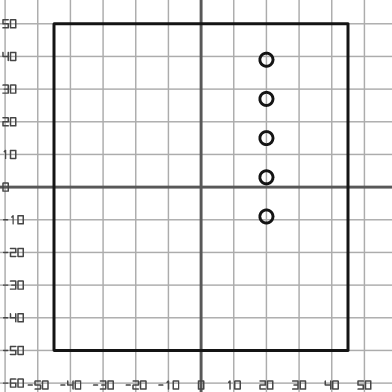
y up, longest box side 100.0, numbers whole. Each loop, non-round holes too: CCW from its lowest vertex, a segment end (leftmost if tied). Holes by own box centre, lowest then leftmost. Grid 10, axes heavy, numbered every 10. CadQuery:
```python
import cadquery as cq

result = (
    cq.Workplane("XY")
    .moveTo(-45.0, -50.0)
    .lineTo(45.0, -50.0)
    .lineTo(45.0, 50.0)
    .lineTo(-45.0, 50.0)
    .close()
    .moveTo(20.0, -9.0)
    .circle(2.0)
    .moveTo(20.0, 3.0)
    .circle(2.0)
    .moveTo(20.0, 15.0)
    .circle(2.0)
    .moveTo(20.0, 27.0)
    .circle(2.0)
    .moveTo(20.0, 39.0)
    .circle(2.0)
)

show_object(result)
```